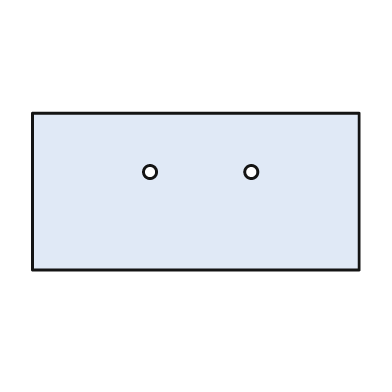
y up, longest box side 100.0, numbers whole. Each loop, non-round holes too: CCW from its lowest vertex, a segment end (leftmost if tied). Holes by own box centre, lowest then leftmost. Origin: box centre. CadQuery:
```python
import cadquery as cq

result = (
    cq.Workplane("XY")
    .moveTo(-50.0, -24.0)
    .lineTo(50.0, -24.0)
    .lineTo(50.0, 24.0)
    .lineTo(-50.0, 24.0)
    .close()
    .moveTo(-14.0, 6.0)
    .circle(2.0)
    .moveTo(17.0, 6.0)
    .circle(2.0)
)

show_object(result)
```